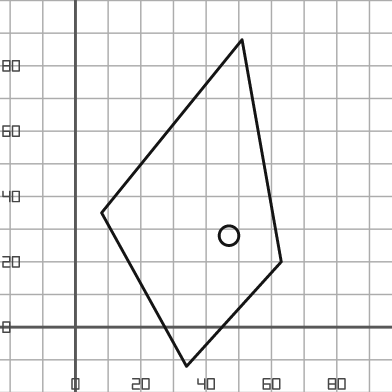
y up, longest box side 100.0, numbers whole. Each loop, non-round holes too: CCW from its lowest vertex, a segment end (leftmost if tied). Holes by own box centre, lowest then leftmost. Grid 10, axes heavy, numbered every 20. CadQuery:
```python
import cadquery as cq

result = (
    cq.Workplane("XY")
    .moveTo(34.0, -12.0)
    .lineTo(63.0, 20.0)
    .lineTo(51.0, 88.0)
    .lineTo(8.0, 35.0)
    .close()
    .moveTo(47.0, 28.0)
    .circle(3.0)
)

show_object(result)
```